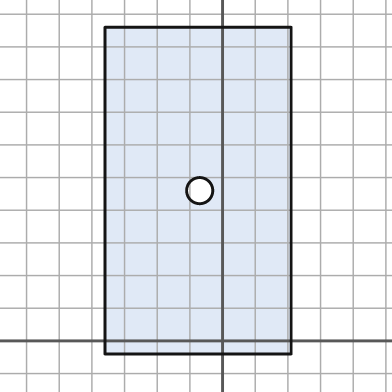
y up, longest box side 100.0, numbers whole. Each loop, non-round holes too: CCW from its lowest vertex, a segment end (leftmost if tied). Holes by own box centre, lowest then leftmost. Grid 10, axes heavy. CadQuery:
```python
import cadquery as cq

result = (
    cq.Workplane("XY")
    .moveTo(-36.0, -4.0)
    .lineTo(21.0, -4.0)
    .lineTo(21.0, 96.0)
    .lineTo(-36.0, 96.0)
    .close()
    .moveTo(-7.0, 46.0)
    .circle(4.0)
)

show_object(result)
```